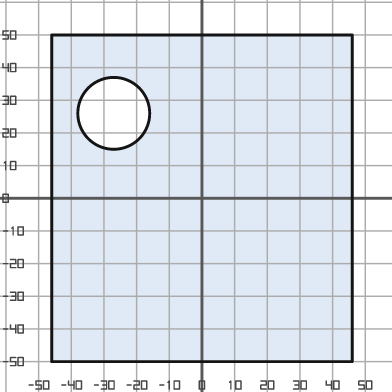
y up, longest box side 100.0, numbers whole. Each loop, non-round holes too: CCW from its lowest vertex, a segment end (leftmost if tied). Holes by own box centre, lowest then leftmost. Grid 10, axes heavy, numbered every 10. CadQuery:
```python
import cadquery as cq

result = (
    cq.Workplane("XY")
    .moveTo(-46.0, -50.0)
    .lineTo(46.0, -50.0)
    .lineTo(46.0, 50.0)
    .lineTo(-46.0, 50.0)
    .close()
    .moveTo(-27.0, 26.0)
    .circle(11.0)
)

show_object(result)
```